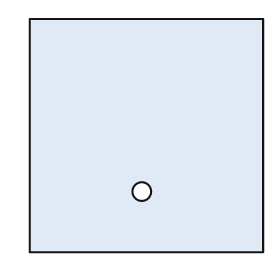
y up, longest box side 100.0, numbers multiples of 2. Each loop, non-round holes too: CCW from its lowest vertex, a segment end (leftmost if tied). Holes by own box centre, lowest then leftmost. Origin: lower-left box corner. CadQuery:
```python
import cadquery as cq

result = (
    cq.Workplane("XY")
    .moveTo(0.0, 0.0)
    .lineTo(100.0, 0.0)
    .lineTo(100.0, 100.0)
    .lineTo(0.0, 100.0)
    .close()
    .moveTo(48.0, 26.0)
    .circle(4.0)
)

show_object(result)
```